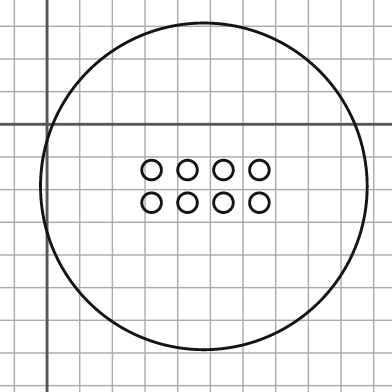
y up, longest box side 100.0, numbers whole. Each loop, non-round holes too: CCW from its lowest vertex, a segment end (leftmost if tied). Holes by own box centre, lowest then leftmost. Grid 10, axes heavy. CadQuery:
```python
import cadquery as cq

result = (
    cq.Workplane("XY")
    .moveTo(48.0, -19.0)
    .circle(50.0)
    .moveTo(32.0, -24.0)
    .circle(3.0)
    .moveTo(43.0, -24.0)
    .circle(3.0)
    .moveTo(54.0, -24.0)
    .circle(3.0)
    .moveTo(65.0, -24.0)
    .circle(3.0)
    .moveTo(32.0, -14.0)
    .circle(3.0)
    .moveTo(43.0, -14.0)
    .circle(3.0)
    .moveTo(54.0, -14.0)
    .circle(3.0)
    .moveTo(65.0, -14.0)
    .circle(3.0)
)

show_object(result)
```